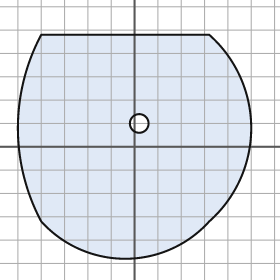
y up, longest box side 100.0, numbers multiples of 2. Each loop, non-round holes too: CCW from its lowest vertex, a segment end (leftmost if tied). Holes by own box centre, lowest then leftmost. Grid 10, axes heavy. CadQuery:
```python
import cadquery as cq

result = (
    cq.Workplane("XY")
    .moveTo(-40.0, -32.0)
    .threePointArc((-4.0, -48.0), (32.0, -32.0))
    .threePointArc((50.0, 8.0), (32.0, 48.0))
    .lineTo(-40.0, 48.0)
    .threePointArc((-50.0, 8.0), (-40.0, -32.0))
    .close()
    .moveTo(2.0, 10.0)
    .circle(4.0)
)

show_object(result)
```